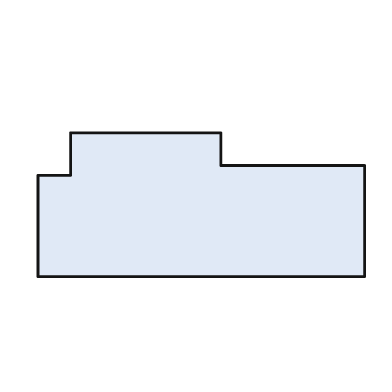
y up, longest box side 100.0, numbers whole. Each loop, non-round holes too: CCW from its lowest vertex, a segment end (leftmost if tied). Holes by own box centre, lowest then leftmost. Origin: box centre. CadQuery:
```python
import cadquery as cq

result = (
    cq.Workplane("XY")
    .moveTo(-50.0, -22.0)
    .lineTo(50.0, -22.0)
    .lineTo(50.0, 12.0)
    .lineTo(6.0, 12.0)
    .lineTo(6.0, 22.0)
    .lineTo(-40.0, 22.0)
    .lineTo(-40.0, 9.0)
    .lineTo(-50.0, 9.0)
    .close()
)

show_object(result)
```